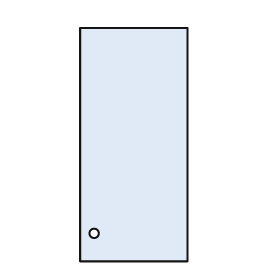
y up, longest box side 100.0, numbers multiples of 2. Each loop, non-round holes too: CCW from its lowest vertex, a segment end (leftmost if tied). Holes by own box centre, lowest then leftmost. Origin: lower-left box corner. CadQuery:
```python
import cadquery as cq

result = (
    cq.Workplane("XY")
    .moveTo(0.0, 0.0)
    .lineTo(46.0, 0.0)
    .lineTo(46.0, 100.0)
    .lineTo(0.0, 100.0)
    .close()
    .moveTo(6.0, 12.0)
    .circle(2.0)
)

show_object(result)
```